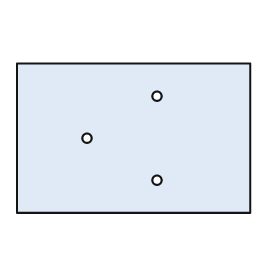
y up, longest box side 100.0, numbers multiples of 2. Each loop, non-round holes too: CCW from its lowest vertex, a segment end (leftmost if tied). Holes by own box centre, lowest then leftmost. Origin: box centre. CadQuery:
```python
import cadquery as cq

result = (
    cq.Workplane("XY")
    .moveTo(-50.0, -32.0)
    .lineTo(50.0, -32.0)
    .lineTo(50.0, 32.0)
    .lineTo(-50.0, 32.0)
    .close()
    .moveTo(10.0, -18.0)
    .circle(2.0)
    .moveTo(-20.0, 0.0)
    .circle(2.0)
    .moveTo(10.0, 18.0)
    .circle(2.0)
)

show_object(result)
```